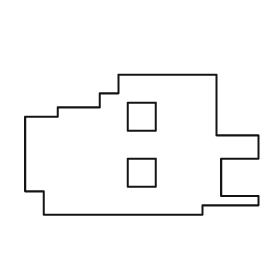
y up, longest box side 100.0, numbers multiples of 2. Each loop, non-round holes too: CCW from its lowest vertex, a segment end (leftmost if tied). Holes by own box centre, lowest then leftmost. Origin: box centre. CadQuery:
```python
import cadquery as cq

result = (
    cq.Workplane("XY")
    .moveTo(-42.0, -30.0)
    .lineTo(26.0, -30.0)
    .lineTo(26.0, -26.0)
    .lineTo(50.0, -26.0)
    .lineTo(50.0, -22.0)
    .lineTo(34.0, -22.0)
    .lineTo(34.0, -6.0)
    .lineTo(50.0, -6.0)
    .lineTo(50.0, 4.0)
    .lineTo(32.0, 4.0)
    .lineTo(32.0, 30.0)
    .lineTo(-10.0, 30.0)
    .lineTo(-10.0, 22.0)
    .lineTo(-18.0, 22.0)
    .lineTo(-18.0, 16.0)
    .lineTo(-36.0, 16.0)
    .lineTo(-36.0, 12.0)
    .lineTo(-50.0, 12.0)
    .lineTo(-50.0, -20.0)
    .lineTo(-42.0, -20.0)
    .close()
    .moveTo(-6.0, -18.0)
    .lineTo(6.0, -18.0)
    .lineTo(6.0, -6.0)
    .lineTo(-6.0, -6.0)
    .close()
    .moveTo(-6.0, 6.0)
    .lineTo(6.0, 6.0)
    .lineTo(6.0, 18.0)
    .lineTo(-6.0, 18.0)
    .close()
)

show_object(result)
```